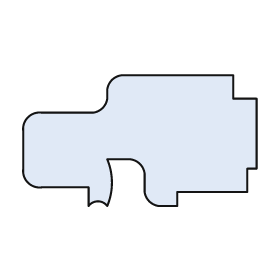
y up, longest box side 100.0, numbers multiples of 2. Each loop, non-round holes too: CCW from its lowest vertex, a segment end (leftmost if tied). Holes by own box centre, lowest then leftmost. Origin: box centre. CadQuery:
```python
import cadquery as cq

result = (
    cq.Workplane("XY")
    .moveTo(-22.0, -28.0)
    .threePointArc((-18.0, -26.0), (-14.0, -28.0))
    .threePointArc((-12.0, -18.0), (-14.0, -8.0))
    .lineTo(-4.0, -8.0)
    .threePointArc((0.0, -10.0), (2.0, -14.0))
    .lineTo(2.0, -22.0)
    .threePointArc((4.0, -26.0), (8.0, -28.0))
    .lineTo(16.0, -28.0)
    .lineTo(16.0, -22.0)
    .lineTo(46.0, -22.0)
    .lineTo(46.0, -12.0)
    .lineTo(50.0, -12.0)
    .lineTo(50.0, 18.0)
    .lineTo(40.0, 18.0)
    .lineTo(40.0, 28.0)
    .lineTo(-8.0, 28.0)
    .threePointArc((-12.0, 26.0), (-14.0, 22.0))
    .lineTo(-14.0, 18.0)
    .threePointArc((-16.0, 14.0), (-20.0, 12.0))
    .lineTo(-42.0, 12.0)
    .threePointArc((-48.0, 10.0), (-50.0, 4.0))
    .lineTo(-50.0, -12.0)
    .threePointArc((-48.0, -18.0), (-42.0, -20.0))
    .lineTo(-22.0, -20.0)
    .close()
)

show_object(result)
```